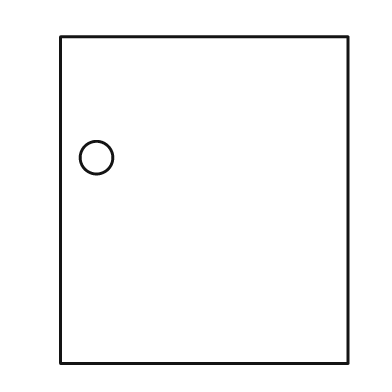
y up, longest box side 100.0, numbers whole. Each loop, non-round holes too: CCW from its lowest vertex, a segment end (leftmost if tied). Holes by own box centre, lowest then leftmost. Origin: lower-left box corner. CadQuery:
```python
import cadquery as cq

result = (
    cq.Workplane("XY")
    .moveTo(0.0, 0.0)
    .lineTo(88.0, 0.0)
    .lineTo(88.0, 100.0)
    .lineTo(0.0, 100.0)
    .close()
    .moveTo(11.0, 63.0)
    .circle(5.0)
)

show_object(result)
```